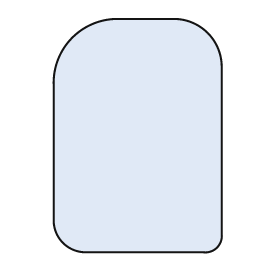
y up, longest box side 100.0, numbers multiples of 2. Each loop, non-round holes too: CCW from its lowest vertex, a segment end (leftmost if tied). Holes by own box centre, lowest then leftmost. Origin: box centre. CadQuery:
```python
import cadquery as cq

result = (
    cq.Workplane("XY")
    .moveTo(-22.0, -50.0)
    .lineTo(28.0, -50.0)
    .threePointArc((34.0, -48.0), (36.0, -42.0))
    .lineTo(36.0, 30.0)
    .threePointArc((30.0, 44.0), (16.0, 50.0))
    .lineTo(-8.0, 50.0)
    .threePointArc((-28.0, 42.0), (-36.0, 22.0))
    .lineTo(-36.0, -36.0)
    .threePointArc((-32.0, -46.0), (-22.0, -50.0))
    .close()
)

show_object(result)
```